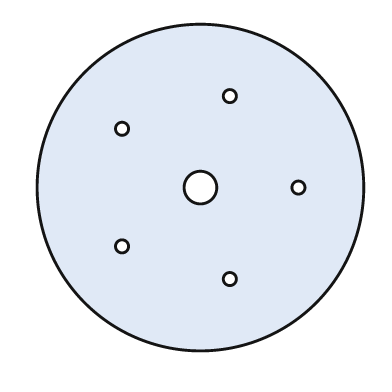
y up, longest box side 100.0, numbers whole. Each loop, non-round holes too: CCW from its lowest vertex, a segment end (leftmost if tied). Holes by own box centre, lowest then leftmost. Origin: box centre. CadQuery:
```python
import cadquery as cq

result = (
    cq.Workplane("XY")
    .moveTo(0.0, 0.0)
    .circle(50.0)
    .moveTo(9.0, -28.0)
    .circle(2.0)
    .moveTo(-24.0, -18.0)
    .circle(2.0)
    .moveTo(0.0, 0.0)
    .circle(5.0)
    .moveTo(30.0, 0.0)
    .circle(2.0)
    .moveTo(-24.0, 18.0)
    .circle(2.0)
    .moveTo(9.0, 28.0)
    .circle(2.0)
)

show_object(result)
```